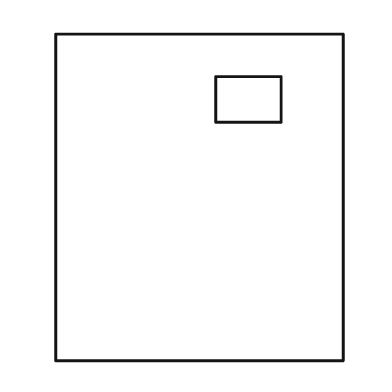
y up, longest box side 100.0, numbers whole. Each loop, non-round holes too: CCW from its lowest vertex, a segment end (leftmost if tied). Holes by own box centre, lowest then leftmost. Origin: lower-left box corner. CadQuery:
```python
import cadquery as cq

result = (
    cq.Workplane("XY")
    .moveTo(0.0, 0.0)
    .lineTo(88.0, 0.0)
    .lineTo(88.0, 100.0)
    .lineTo(0.0, 100.0)
    .close()
    .moveTo(49.0, 73.0)
    .lineTo(69.0, 73.0)
    .lineTo(69.0, 87.0)
    .lineTo(49.0, 87.0)
    .close()
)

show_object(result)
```